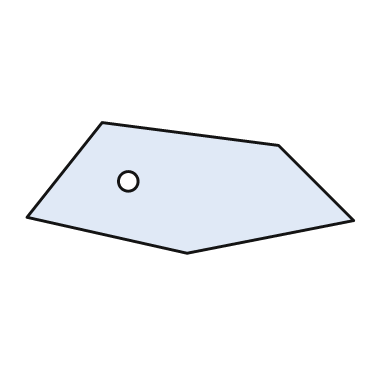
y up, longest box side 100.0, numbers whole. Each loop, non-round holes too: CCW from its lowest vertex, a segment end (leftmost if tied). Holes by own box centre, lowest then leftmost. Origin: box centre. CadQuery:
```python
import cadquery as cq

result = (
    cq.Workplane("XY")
    .moveTo(-1.0, -20.0)
    .lineTo(50.0, -10.0)
    .lineTo(27.0, 13.0)
    .lineTo(-27.0, 20.0)
    .lineTo(-50.0, -9.0)
    .close()
    .moveTo(-19.0, 2.0)
    .circle(3.0)
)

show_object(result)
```